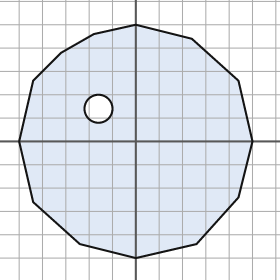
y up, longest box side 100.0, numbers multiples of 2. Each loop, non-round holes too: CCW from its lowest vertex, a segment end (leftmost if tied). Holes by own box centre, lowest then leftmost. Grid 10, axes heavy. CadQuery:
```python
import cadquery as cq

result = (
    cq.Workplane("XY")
    .moveTo(0.0, -50.0)
    .lineTo(26.0, -44.0)
    .lineTo(44.0, -24.0)
    .lineTo(50.0, 0.0)
    .lineTo(44.0, 26.0)
    .lineTo(24.0, 44.0)
    .lineTo(0.0, 50.0)
    .lineTo(-18.0, 46.0)
    .lineTo(-32.0, 38.0)
    .lineTo(-44.0, 26.0)
    .lineTo(-50.0, 0.0)
    .lineTo(-44.0, -26.0)
    .lineTo(-24.0, -44.0)
    .close()
    .moveTo(-16.0, 14.0)
    .circle(6.0)
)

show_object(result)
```